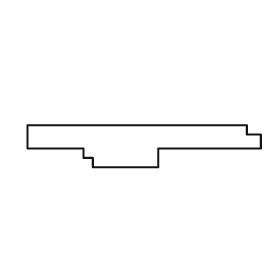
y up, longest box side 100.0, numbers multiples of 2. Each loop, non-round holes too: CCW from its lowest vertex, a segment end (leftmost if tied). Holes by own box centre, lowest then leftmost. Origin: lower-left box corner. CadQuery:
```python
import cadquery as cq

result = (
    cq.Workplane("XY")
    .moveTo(28.0, 0.0)
    .lineTo(56.0, 0.0)
    .lineTo(56.0, 8.0)
    .lineTo(100.0, 8.0)
    .lineTo(100.0, 14.0)
    .lineTo(94.0, 14.0)
    .lineTo(94.0, 18.0)
    .lineTo(0.0, 18.0)
    .lineTo(0.0, 8.0)
    .lineTo(24.0, 8.0)
    .lineTo(24.0, 4.0)
    .lineTo(28.0, 4.0)
    .close()
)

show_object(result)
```